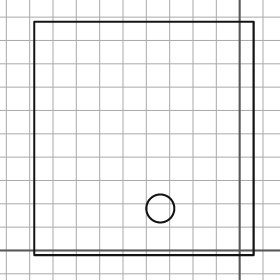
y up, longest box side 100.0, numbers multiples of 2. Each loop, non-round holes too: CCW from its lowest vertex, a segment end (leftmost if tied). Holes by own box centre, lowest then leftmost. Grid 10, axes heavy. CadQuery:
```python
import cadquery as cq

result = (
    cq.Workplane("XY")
    .moveTo(-88.0, -2.0)
    .lineTo(6.0, -2.0)
    .lineTo(6.0, 98.0)
    .lineTo(-88.0, 98.0)
    .close()
    .moveTo(-34.0, 18.0)
    .circle(6.0)
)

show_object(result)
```